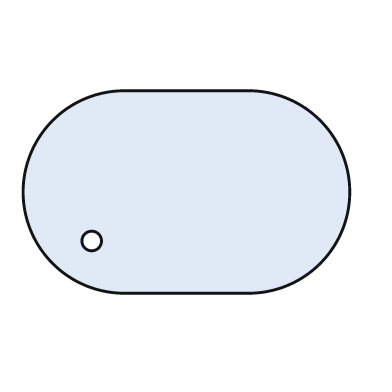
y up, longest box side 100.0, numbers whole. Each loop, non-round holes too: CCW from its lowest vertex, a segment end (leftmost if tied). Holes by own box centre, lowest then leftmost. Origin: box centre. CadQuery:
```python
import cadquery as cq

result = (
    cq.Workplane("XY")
    .moveTo(-19.0, -31.0)
    .lineTo(19.0, -31.0)
    .threePointArc((50.0, 0.0), (19.0, 31.0))
    .lineTo(-19.0, 31.0)
    .threePointArc((-50.0, 0.0), (-19.0, -31.0))
    .close()
    .moveTo(-29.0, -15.0)
    .circle(3.0)
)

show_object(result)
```